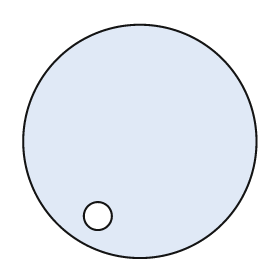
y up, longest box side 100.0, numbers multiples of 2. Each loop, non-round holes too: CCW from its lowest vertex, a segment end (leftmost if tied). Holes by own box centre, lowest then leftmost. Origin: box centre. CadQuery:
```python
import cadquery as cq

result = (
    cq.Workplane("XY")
    .moveTo(0.0, 0.0)
    .circle(50.0)
    .moveTo(-18.0, -32.0)
    .circle(6.0)
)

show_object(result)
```